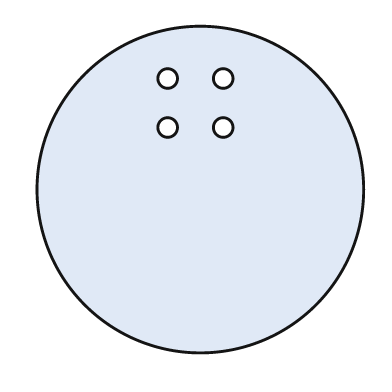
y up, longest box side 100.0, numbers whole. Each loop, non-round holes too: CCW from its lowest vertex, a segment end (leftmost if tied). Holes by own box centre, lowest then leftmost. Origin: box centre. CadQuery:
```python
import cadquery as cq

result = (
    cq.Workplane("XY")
    .moveTo(0.0, 0.0)
    .circle(50.0)
    .moveTo(-10.0, 19.0)
    .circle(3.0)
    .moveTo(7.0, 19.0)
    .circle(3.0)
    .moveTo(-10.0, 34.0)
    .circle(3.0)
    .moveTo(7.0, 34.0)
    .circle(3.0)
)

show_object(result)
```